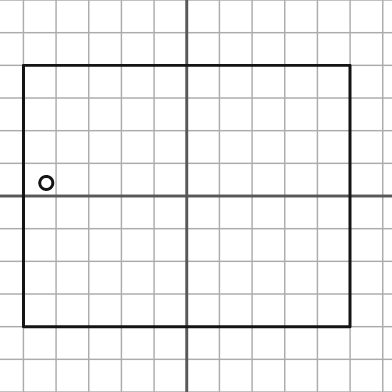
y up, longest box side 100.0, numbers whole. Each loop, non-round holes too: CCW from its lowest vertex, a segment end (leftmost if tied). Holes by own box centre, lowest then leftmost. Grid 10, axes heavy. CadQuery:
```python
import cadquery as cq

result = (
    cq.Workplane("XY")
    .moveTo(-50.0, -40.0)
    .lineTo(50.0, -40.0)
    .lineTo(50.0, 40.0)
    .lineTo(-50.0, 40.0)
    .close()
    .moveTo(-43.0, 4.0)
    .circle(2.0)
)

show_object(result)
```